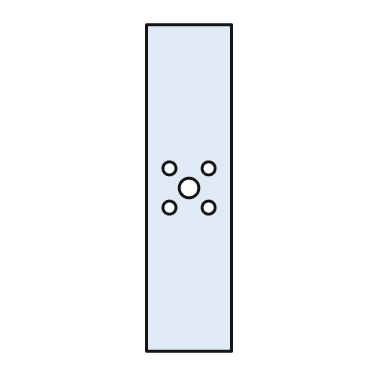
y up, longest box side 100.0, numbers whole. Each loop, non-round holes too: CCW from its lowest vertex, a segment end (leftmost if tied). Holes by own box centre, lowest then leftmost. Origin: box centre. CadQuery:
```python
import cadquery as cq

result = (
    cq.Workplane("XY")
    .moveTo(-13.0, -50.0)
    .lineTo(13.0, -50.0)
    .lineTo(13.0, 50.0)
    .lineTo(-13.0, 50.0)
    .close()
    .moveTo(-6.0, -6.0)
    .circle(2.0)
    .moveTo(6.0, -6.0)
    .circle(2.0)
    .moveTo(0.0, 0.0)
    .circle(3.0)
    .moveTo(-6.0, 6.0)
    .circle(2.0)
    .moveTo(6.0, 6.0)
    .circle(2.0)
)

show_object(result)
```